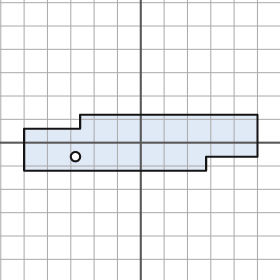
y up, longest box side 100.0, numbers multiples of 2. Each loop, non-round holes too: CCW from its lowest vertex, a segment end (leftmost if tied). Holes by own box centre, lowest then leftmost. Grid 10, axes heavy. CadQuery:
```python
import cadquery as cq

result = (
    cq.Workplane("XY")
    .moveTo(-50.0, -12.0)
    .lineTo(28.0, -12.0)
    .lineTo(28.0, -6.0)
    .lineTo(50.0, -6.0)
    .lineTo(50.0, 12.0)
    .lineTo(-26.0, 12.0)
    .lineTo(-26.0, 6.0)
    .lineTo(-50.0, 6.0)
    .close()
    .moveTo(-28.0, -6.0)
    .circle(2.0)
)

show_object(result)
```